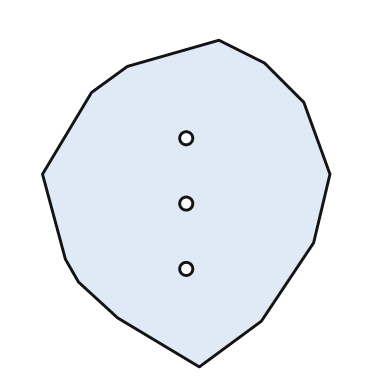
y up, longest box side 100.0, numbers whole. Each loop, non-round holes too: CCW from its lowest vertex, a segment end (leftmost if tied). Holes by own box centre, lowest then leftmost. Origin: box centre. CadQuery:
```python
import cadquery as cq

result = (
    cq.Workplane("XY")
    .moveTo(4.0, -50.0)
    .lineTo(23.0, -36.0)
    .lineTo(39.0, -12.0)
    .lineTo(44.0, 9.0)
    .lineTo(36.0, 31.0)
    .lineTo(24.0, 43.0)
    .lineTo(10.0, 50.0)
    .lineTo(-18.0, 42.0)
    .lineTo(-29.0, 34.0)
    .lineTo(-44.0, 9.0)
    .lineTo(-37.0, -17.0)
    .lineTo(-33.0, -24.0)
    .lineTo(-21.0, -35.0)
    .close()
    .moveTo(0.0, -20.0)
    .circle(2.0)
    .moveTo(0.0, 0.0)
    .circle(2.0)
    .moveTo(0.0, 20.0)
    .circle(2.0)
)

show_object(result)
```